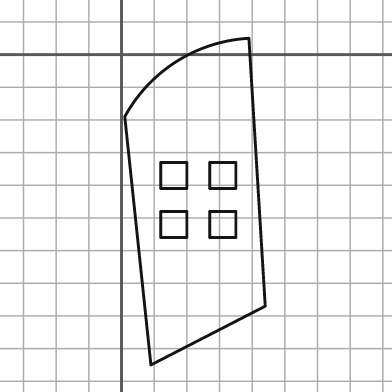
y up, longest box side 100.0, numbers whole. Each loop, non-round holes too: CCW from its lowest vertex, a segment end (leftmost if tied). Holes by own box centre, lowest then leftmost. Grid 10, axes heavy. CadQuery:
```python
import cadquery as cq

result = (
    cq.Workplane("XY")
    .moveTo(9.0, -95.0)
    .lineTo(44.0, -77.0)
    .lineTo(39.0, 5.0)
    .threePointArc((17.0, -2.0), (1.0, -19.0))
    .close()
    .moveTo(12.0, -56.0)
    .lineTo(20.0, -56.0)
    .lineTo(20.0, -48.0)
    .lineTo(12.0, -48.0)
    .close()
    .moveTo(27.0, -56.0)
    .lineTo(35.0, -56.0)
    .lineTo(35.0, -48.0)
    .lineTo(27.0, -48.0)
    .close()
    .moveTo(12.0, -41.0)
    .lineTo(20.0, -41.0)
    .lineTo(20.0, -33.0)
    .lineTo(12.0, -33.0)
    .close()
    .moveTo(27.0, -41.0)
    .lineTo(35.0, -41.0)
    .lineTo(35.0, -33.0)
    .lineTo(27.0, -33.0)
    .close()
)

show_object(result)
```